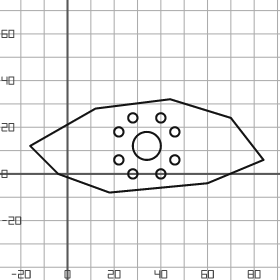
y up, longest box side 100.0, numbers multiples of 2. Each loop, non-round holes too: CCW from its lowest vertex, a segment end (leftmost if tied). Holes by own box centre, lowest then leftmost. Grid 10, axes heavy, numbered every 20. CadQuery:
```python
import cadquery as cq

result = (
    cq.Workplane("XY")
    .moveTo(18.0, -8.0)
    .lineTo(60.0, -4.0)
    .lineTo(84.0, 6.0)
    .lineTo(70.0, 24.0)
    .lineTo(44.0, 32.0)
    .lineTo(12.0, 28.0)
    .lineTo(-16.0, 12.0)
    .lineTo(-4.0, 0.0)
    .close()
    .moveTo(28.0, 0.0)
    .circle(2.0)
    .moveTo(40.0, 0.0)
    .circle(2.0)
    .moveTo(22.0, 6.0)
    .circle(2.0)
    .moveTo(46.0, 6.0)
    .circle(2.0)
    .moveTo(34.0, 12.0)
    .circle(6.0)
    .moveTo(22.0, 18.0)
    .circle(2.0)
    .moveTo(46.0, 18.0)
    .circle(2.0)
    .moveTo(28.0, 24.0)
    .circle(2.0)
    .moveTo(40.0, 24.0)
    .circle(2.0)
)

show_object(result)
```